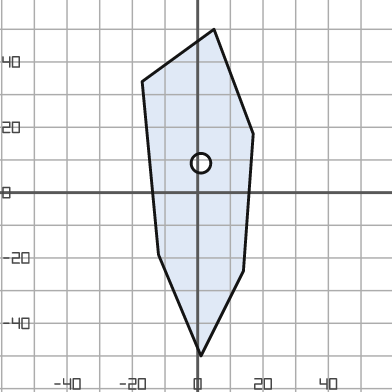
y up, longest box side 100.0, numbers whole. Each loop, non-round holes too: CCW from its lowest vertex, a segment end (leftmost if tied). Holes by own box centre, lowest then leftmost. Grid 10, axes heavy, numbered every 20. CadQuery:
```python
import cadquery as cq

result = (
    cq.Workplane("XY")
    .moveTo(1.0, -50.0)
    .lineTo(14.0, -24.0)
    .lineTo(17.0, 18.0)
    .lineTo(5.0, 50.0)
    .lineTo(-17.0, 34.0)
    .lineTo(-12.0, -19.0)
    .close()
    .moveTo(1.0, 9.0)
    .circle(3.0)
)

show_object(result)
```